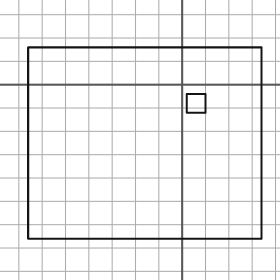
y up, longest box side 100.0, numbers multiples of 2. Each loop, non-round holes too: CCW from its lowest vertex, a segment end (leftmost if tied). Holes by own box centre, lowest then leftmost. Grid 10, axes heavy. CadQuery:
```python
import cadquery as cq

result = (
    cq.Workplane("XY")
    .moveTo(-66.0, -66.0)
    .lineTo(34.0, -66.0)
    .lineTo(34.0, 16.0)
    .lineTo(-66.0, 16.0)
    .close()
    .moveTo(2.0, -12.0)
    .lineTo(10.0, -12.0)
    .lineTo(10.0, -4.0)
    .lineTo(2.0, -4.0)
    .close()
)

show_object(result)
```